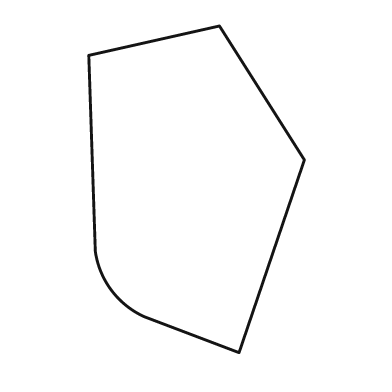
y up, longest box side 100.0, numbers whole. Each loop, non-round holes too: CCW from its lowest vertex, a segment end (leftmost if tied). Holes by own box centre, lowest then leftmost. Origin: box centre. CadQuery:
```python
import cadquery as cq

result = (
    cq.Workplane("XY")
    .moveTo(13.0, -50.0)
    .lineTo(33.0, 9.0)
    .lineTo(7.0, 50.0)
    .lineTo(-33.0, 41.0)
    .lineTo(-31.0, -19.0)
    .threePointArc((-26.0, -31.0), (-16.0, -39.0))
    .close()
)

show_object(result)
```